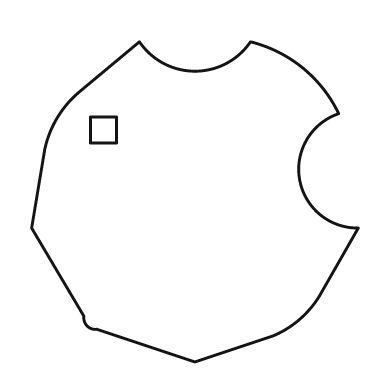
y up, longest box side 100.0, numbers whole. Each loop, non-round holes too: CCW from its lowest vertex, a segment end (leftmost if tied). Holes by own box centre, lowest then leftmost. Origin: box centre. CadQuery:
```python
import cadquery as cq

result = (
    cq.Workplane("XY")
    .moveTo(0.0, -49.0)
    .lineTo(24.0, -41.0)
    .threePointArc((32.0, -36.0), (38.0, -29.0))
    .lineTo(50.0, -8.0)
    .threePointArc((32.0, 7.0), (44.0, 27.0))
    .threePointArc((33.0, 41.0), (17.0, 49.0))
    .threePointArc((0.0, 40.0), (-17.0, 49.0))
    .lineTo(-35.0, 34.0)
    .threePointArc((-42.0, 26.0), (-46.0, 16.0))
    .lineTo(-50.0, -8.0)
    .lineTo(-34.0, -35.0)
    .threePointArc((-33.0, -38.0), (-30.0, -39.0))
    .close()
    .moveTo(-32.0, 18.0)
    .lineTo(-24.0, 18.0)
    .lineTo(-24.0, 26.0)
    .lineTo(-32.0, 26.0)
    .close()
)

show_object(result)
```